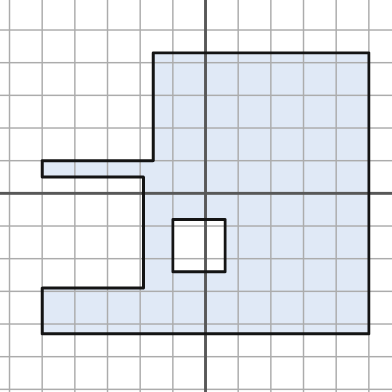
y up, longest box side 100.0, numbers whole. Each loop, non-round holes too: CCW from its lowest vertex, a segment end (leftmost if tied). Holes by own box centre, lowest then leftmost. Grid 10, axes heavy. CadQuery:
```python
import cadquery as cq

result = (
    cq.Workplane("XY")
    .moveTo(-50.0, -43.0)
    .lineTo(50.0, -43.0)
    .lineTo(50.0, 43.0)
    .lineTo(-16.0, 43.0)
    .lineTo(-16.0, 10.0)
    .lineTo(-50.0, 10.0)
    .lineTo(-50.0, 5.0)
    .lineTo(-19.0, 5.0)
    .lineTo(-19.0, -29.0)
    .lineTo(-50.0, -29.0)
    .close()
    .moveTo(-10.0, -24.0)
    .lineTo(6.0, -24.0)
    .lineTo(6.0, -8.0)
    .lineTo(-10.0, -8.0)
    .close()
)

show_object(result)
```